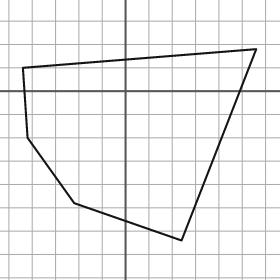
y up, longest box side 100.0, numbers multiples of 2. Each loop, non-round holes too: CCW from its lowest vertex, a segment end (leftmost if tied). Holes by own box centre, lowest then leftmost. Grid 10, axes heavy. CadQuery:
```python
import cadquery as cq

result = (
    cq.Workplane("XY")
    .moveTo(24.0, -64.0)
    .lineTo(56.0, 18.0)
    .lineTo(-44.0, 10.0)
    .lineTo(-42.0, -20.0)
    .lineTo(-22.0, -48.0)
    .close()
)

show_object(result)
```